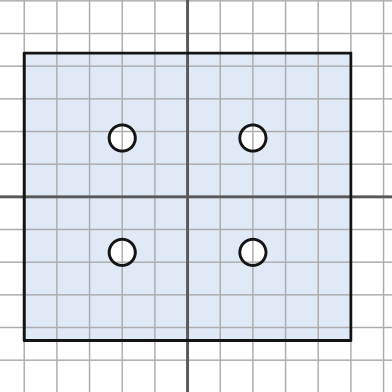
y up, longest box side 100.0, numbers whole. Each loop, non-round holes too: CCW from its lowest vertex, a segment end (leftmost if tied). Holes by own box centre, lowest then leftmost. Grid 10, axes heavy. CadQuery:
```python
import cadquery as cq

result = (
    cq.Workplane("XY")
    .moveTo(-50.0, -44.0)
    .lineTo(50.0, -44.0)
    .lineTo(50.0, 44.0)
    .lineTo(-50.0, 44.0)
    .close()
    .moveTo(-20.0, -17.0)
    .circle(4.0)
    .moveTo(20.0, -17.0)
    .circle(4.0)
    .moveTo(-20.0, 18.0)
    .circle(4.0)
    .moveTo(20.0, 18.0)
    .circle(4.0)
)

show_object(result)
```